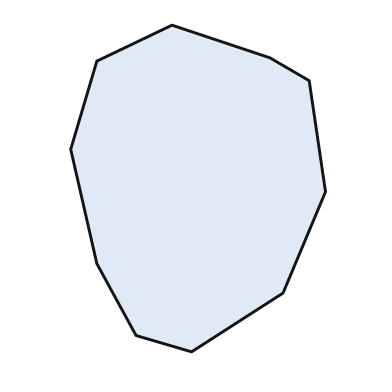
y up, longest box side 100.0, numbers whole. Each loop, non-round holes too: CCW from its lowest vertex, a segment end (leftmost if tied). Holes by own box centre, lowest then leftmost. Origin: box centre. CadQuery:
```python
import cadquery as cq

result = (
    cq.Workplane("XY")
    .moveTo(-2.0, -50.0)
    .lineTo(26.0, -32.0)
    .lineTo(39.0, -1.0)
    .lineTo(34.0, 33.0)
    .lineTo(22.0, 40.0)
    .lineTo(-8.0, 50.0)
    .lineTo(-31.0, 39.0)
    .lineTo(-39.0, 12.0)
    .lineTo(-31.0, -23.0)
    .lineTo(-19.0, -45.0)
    .close()
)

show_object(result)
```